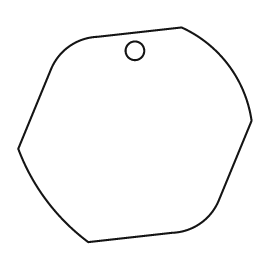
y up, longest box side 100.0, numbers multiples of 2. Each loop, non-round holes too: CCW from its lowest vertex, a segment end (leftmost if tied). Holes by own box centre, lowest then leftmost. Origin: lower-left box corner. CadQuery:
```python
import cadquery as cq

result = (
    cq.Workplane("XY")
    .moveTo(30.0, 0.0)
    .lineTo(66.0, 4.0)
    .threePointArc((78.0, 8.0), (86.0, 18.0))
    .lineTo(100.0, 52.0)
    .threePointArc((90.0, 76.0), (70.0, 92.0))
    .lineTo(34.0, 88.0)
    .threePointArc((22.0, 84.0), (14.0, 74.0))
    .lineTo(0.0, 40.0)
    .threePointArc((12.0, 18.0), (30.0, 0.0))
    .close()
    .moveTo(50.0, 82.0)
    .circle(4.0)
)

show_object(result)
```